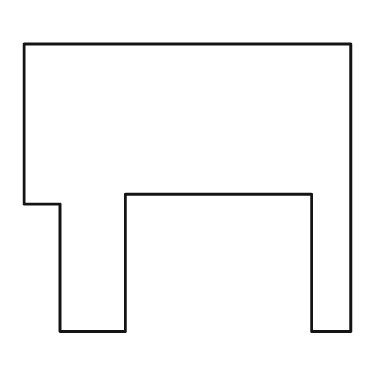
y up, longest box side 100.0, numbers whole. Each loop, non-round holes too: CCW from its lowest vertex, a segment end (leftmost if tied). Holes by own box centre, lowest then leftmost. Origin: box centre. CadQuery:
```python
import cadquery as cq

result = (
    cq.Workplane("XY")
    .moveTo(-39.0, -44.0)
    .lineTo(-19.0, -44.0)
    .lineTo(-19.0, -2.0)
    .lineTo(38.0, -2.0)
    .lineTo(38.0, -44.0)
    .lineTo(50.0, -44.0)
    .lineTo(50.0, 44.0)
    .lineTo(-50.0, 44.0)
    .lineTo(-50.0, -5.0)
    .lineTo(-39.0, -5.0)
    .close()
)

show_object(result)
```